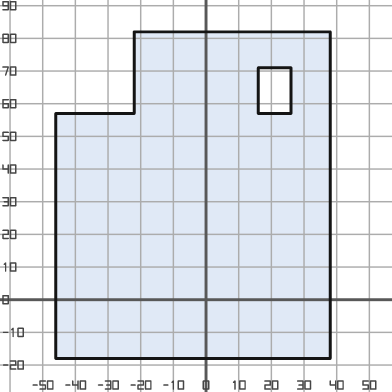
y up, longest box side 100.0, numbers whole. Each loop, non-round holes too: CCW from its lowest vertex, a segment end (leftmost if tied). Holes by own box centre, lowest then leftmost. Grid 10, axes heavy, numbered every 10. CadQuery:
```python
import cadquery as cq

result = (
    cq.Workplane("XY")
    .moveTo(-46.0, -18.0)
    .lineTo(38.0, -18.0)
    .lineTo(38.0, 82.0)
    .lineTo(-22.0, 82.0)
    .lineTo(-22.0, 57.0)
    .lineTo(-46.0, 57.0)
    .close()
    .moveTo(16.0, 57.0)
    .lineTo(26.0, 57.0)
    .lineTo(26.0, 71.0)
    .lineTo(16.0, 71.0)
    .close()
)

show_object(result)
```